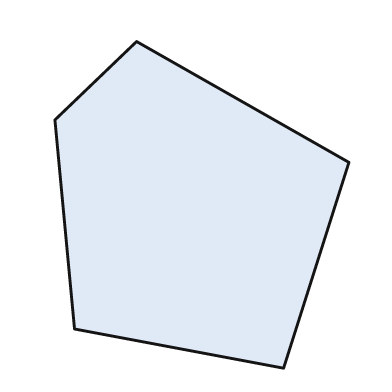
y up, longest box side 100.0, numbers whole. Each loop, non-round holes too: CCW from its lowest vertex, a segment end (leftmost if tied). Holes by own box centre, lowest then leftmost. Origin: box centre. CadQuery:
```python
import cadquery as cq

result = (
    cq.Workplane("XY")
    .moveTo(25.0, -50.0)
    .lineTo(45.0, 13.0)
    .lineTo(-20.0, 50.0)
    .lineTo(-45.0, 26.0)
    .lineTo(-39.0, -38.0)
    .close()
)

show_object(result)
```